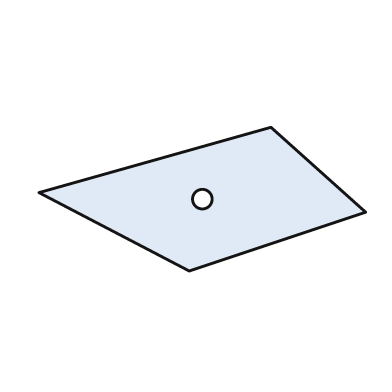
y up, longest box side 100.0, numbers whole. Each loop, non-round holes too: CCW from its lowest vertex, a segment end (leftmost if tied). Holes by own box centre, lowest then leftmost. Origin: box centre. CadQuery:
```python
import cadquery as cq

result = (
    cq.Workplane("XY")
    .moveTo(-4.0, -22.0)
    .lineTo(50.0, -4.0)
    .lineTo(21.0, 22.0)
    .lineTo(-50.0, 2.0)
    .close()
    .moveTo(0.0, 0.0)
    .circle(3.0)
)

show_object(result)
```